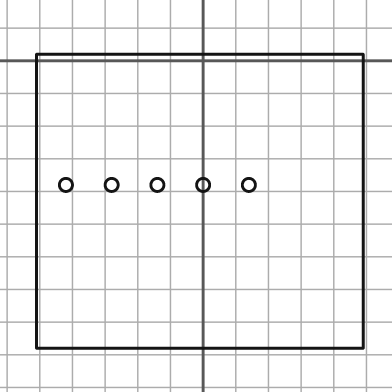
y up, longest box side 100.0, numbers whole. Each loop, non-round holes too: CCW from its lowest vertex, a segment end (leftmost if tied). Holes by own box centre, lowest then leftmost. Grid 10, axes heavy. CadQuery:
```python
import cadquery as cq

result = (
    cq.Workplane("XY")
    .moveTo(-51.0, -88.0)
    .lineTo(49.0, -88.0)
    .lineTo(49.0, 2.0)
    .lineTo(-51.0, 2.0)
    .close()
    .moveTo(-42.0, -38.0)
    .circle(2.0)
    .moveTo(-28.0, -38.0)
    .circle(2.0)
    .moveTo(-14.0, -38.0)
    .circle(2.0)
    .moveTo(0.0, -38.0)
    .circle(2.0)
    .moveTo(14.0, -38.0)
    .circle(2.0)
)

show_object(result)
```